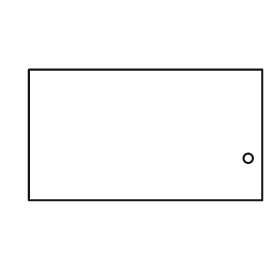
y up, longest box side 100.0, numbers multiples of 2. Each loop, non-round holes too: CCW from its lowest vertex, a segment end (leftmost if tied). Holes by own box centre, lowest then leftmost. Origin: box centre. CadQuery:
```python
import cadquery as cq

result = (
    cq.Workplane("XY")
    .moveTo(-50.0, -28.0)
    .lineTo(50.0, -28.0)
    .lineTo(50.0, 28.0)
    .lineTo(-50.0, 28.0)
    .close()
    .moveTo(44.0, -10.0)
    .circle(2.0)
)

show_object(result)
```